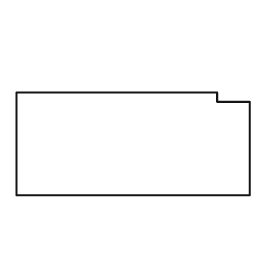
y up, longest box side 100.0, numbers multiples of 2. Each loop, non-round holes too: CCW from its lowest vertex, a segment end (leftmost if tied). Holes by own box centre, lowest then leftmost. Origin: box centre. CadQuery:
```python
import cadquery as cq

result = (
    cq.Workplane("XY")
    .moveTo(-50.0, -22.0)
    .lineTo(50.0, -22.0)
    .lineTo(50.0, 18.0)
    .lineTo(36.0, 18.0)
    .lineTo(36.0, 22.0)
    .lineTo(-50.0, 22.0)
    .close()
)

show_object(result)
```